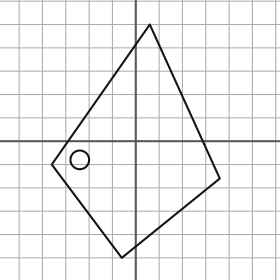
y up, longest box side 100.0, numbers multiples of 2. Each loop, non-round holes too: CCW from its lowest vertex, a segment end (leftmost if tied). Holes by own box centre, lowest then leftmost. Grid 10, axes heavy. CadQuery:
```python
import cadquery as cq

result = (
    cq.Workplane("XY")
    .moveTo(-6.0, -50.0)
    .lineTo(36.0, -16.0)
    .lineTo(6.0, 50.0)
    .lineTo(-36.0, -10.0)
    .close()
    .moveTo(-24.0, -8.0)
    .circle(4.0)
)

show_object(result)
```